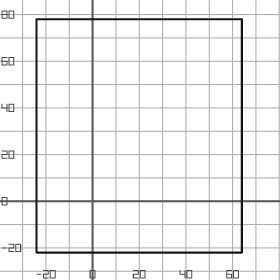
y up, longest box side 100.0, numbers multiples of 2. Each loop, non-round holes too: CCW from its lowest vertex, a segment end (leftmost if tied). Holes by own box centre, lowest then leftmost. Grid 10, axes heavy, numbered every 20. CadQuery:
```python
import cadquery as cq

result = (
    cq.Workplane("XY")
    .moveTo(-24.0, -22.0)
    .lineTo(64.0, -22.0)
    .lineTo(64.0, 78.0)
    .lineTo(-24.0, 78.0)
    .close()
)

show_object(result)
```